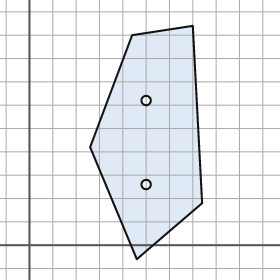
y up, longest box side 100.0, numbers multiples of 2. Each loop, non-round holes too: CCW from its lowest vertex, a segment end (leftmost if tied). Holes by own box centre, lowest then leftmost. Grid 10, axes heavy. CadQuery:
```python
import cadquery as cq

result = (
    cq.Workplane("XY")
    .moveTo(46.0, -6.0)
    .lineTo(74.0, 18.0)
    .lineTo(70.0, 94.0)
    .lineTo(44.0, 90.0)
    .lineTo(26.0, 42.0)
    .close()
    .moveTo(50.0, 26.0)
    .circle(2.0)
    .moveTo(50.0, 62.0)
    .circle(2.0)
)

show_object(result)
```